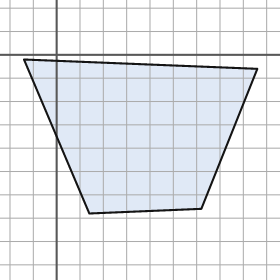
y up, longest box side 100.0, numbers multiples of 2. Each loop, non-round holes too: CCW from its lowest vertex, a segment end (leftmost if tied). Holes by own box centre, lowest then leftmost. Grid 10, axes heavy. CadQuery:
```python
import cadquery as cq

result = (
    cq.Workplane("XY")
    .moveTo(14.0, -68.0)
    .lineTo(62.0, -66.0)
    .lineTo(86.0, -6.0)
    .lineTo(-14.0, -2.0)
    .close()
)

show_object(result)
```